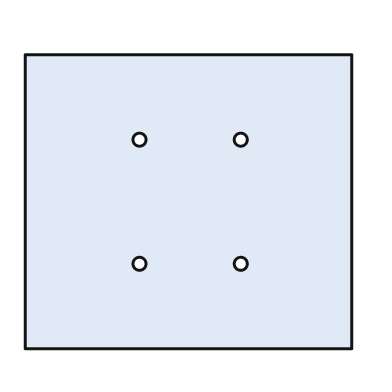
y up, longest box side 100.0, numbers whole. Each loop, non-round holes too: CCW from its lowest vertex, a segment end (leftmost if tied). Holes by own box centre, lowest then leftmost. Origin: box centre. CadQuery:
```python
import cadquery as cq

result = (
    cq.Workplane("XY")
    .moveTo(-50.0, -45.0)
    .lineTo(50.0, -45.0)
    .lineTo(50.0, 45.0)
    .lineTo(-50.0, 45.0)
    .close()
    .moveTo(-15.0, -19.0)
    .circle(2.0)
    .moveTo(16.0, -19.0)
    .circle(2.0)
    .moveTo(-15.0, 19.0)
    .circle(2.0)
    .moveTo(16.0, 19.0)
    .circle(2.0)
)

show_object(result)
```